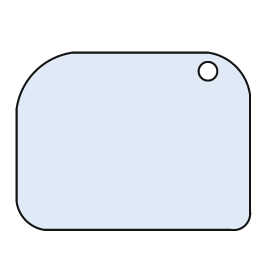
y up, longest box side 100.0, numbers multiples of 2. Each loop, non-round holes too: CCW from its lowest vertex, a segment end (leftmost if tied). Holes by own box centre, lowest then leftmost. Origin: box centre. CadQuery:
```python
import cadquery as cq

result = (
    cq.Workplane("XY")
    .moveTo(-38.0, -38.0)
    .lineTo(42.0, -38.0)
    .threePointArc((48.0, -36.0), (50.0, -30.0))
    .lineTo(50.0, 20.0)
    .threePointArc((44.0, 32.0), (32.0, 38.0))
    .lineTo(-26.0, 38.0)
    .threePointArc((-42.0, 30.0), (-50.0, 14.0))
    .lineTo(-50.0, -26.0)
    .threePointArc((-46.0, -34.0), (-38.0, -38.0))
    .close()
    .moveTo(32.0, 30.0)
    .circle(4.0)
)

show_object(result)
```